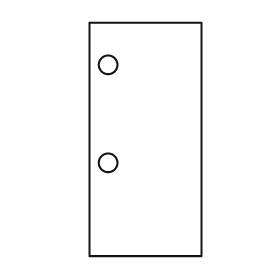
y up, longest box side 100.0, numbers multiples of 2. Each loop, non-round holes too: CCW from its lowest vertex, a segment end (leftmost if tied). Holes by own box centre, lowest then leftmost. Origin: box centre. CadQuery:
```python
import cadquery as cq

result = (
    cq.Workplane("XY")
    .moveTo(-24.0, -50.0)
    .lineTo(24.0, -50.0)
    .lineTo(24.0, 50.0)
    .lineTo(-24.0, 50.0)
    .close()
    .moveTo(-16.0, -10.0)
    .circle(4.0)
    .moveTo(-16.0, 32.0)
    .circle(4.0)
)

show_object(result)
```